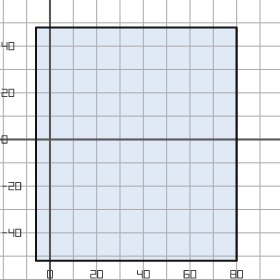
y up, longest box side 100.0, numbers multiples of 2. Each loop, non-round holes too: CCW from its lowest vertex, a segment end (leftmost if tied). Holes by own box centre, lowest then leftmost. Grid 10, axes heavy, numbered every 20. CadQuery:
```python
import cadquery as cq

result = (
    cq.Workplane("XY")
    .moveTo(-6.0, -52.0)
    .lineTo(80.0, -52.0)
    .lineTo(80.0, 48.0)
    .lineTo(-6.0, 48.0)
    .close()
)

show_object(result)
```